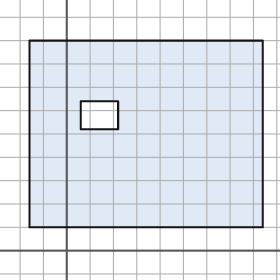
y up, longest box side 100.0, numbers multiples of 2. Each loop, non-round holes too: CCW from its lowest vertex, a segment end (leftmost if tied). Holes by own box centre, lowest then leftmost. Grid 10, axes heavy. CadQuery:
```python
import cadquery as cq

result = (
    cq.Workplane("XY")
    .moveTo(-16.0, 10.0)
    .lineTo(84.0, 10.0)
    .lineTo(84.0, 90.0)
    .lineTo(-16.0, 90.0)
    .close()
    .moveTo(6.0, 52.0)
    .lineTo(22.0, 52.0)
    .lineTo(22.0, 64.0)
    .lineTo(6.0, 64.0)
    .close()
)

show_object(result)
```